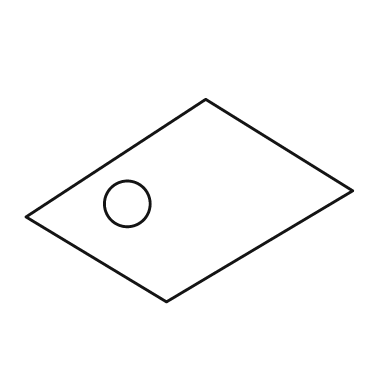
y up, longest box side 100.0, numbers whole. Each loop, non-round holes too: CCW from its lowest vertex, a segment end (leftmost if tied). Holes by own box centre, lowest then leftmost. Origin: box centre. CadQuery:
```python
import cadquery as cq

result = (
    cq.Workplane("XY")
    .moveTo(-7.0, -31.0)
    .lineTo(50.0, 3.0)
    .lineTo(5.0, 31.0)
    .lineTo(-50.0, -5.0)
    .close()
    .moveTo(-19.0, -1.0)
    .circle(7.0)
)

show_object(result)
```